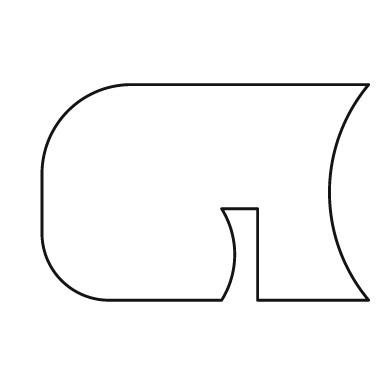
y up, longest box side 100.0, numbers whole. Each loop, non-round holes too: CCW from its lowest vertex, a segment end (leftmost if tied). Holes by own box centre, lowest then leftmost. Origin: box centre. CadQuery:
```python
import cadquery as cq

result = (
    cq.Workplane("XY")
    .moveTo(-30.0, -33.0)
    .lineTo(5.0, -33.0)
    .threePointArc((9.0, -19.0), (5.0, -5.0))
    .lineTo(16.0, -5.0)
    .lineTo(16.0, -33.0)
    .lineTo(50.0, -33.0)
    .threePointArc((38.0, 0.0), (50.0, 33.0))
    .lineTo(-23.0, 33.0)
    .threePointArc((-42.0, 25.0), (-50.0, 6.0))
    .lineTo(-50.0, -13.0)
    .threePointArc((-44.0, -27.0), (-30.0, -33.0))
    .close()
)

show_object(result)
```